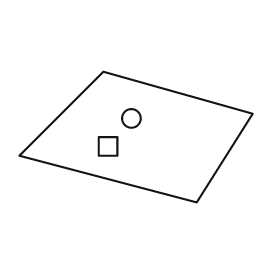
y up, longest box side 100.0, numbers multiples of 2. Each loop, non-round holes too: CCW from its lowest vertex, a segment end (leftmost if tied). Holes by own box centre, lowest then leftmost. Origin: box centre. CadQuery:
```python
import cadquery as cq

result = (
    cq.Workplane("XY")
    .moveTo(26.0, -28.0)
    .lineTo(50.0, 10.0)
    .lineTo(-14.0, 28.0)
    .lineTo(-50.0, -8.0)
    .close()
    .moveTo(-16.0, -8.0)
    .lineTo(-8.0, -8.0)
    .lineTo(-8.0, 0.0)
    .lineTo(-16.0, 0.0)
    .close()
    .moveTo(-2.0, 8.0)
    .circle(4.0)
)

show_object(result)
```